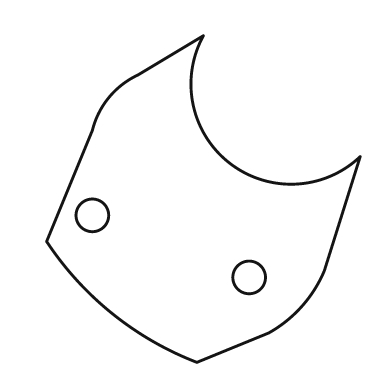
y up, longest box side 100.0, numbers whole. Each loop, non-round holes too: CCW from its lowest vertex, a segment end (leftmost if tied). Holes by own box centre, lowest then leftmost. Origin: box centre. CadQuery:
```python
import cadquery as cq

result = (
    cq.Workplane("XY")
    .moveTo(-2.0, -50.0)
    .lineTo(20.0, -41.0)
    .threePointArc((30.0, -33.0), (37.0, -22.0))
    .lineTo(48.0, 13.0)
    .threePointArc((8.0, 11.0), (0.0, 50.0))
    .lineTo(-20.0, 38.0)
    .threePointArc((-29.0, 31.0), (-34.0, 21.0))
    .lineTo(-48.0, -13.0)
    .threePointArc((-28.0, -35.0), (-2.0, -50.0))
    .close()
    .moveTo(14.0, -24.0)
    .circle(5.0)
    .moveTo(-34.0, -5.0)
    .circle(5.0)
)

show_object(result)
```